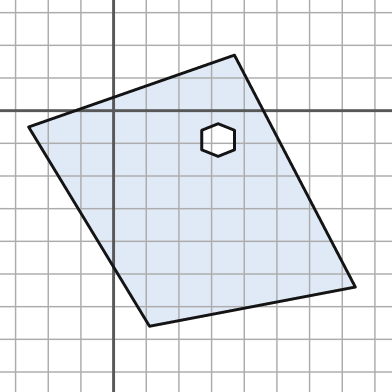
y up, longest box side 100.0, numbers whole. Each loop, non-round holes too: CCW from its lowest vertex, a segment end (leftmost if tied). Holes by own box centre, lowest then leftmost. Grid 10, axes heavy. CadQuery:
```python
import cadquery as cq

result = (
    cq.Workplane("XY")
    .moveTo(11.0, -66.0)
    .lineTo(74.0, -54.0)
    .lineTo(37.0, 17.0)
    .lineTo(-26.0, -5.0)
    .close()
    .moveTo(32.0, -14.0)
    .lineTo(37.0, -12.0)
    .lineTo(37.0, -6.0)
    .lineTo(32.0, -4.0)
    .lineTo(27.0, -6.0)
    .lineTo(27.0, -12.0)
    .close()
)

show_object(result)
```